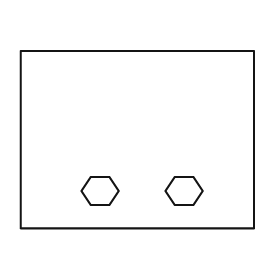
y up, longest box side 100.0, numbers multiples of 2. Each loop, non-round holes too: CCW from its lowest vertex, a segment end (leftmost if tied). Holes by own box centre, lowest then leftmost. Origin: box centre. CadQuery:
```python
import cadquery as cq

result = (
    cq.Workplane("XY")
    .moveTo(-50.0, -38.0)
    .lineTo(50.0, -38.0)
    .lineTo(50.0, 38.0)
    .lineTo(-50.0, 38.0)
    .close()
    .moveTo(-20.0, -28.0)
    .lineTo(-12.0, -28.0)
    .lineTo(-8.0, -22.0)
    .lineTo(-12.0, -16.0)
    .lineTo(-20.0, -16.0)
    .lineTo(-24.0, -22.0)
    .close()
    .moveTo(16.0, -28.0)
    .lineTo(24.0, -28.0)
    .lineTo(28.0, -22.0)
    .lineTo(24.0, -16.0)
    .lineTo(16.0, -16.0)
    .lineTo(12.0, -22.0)
    .close()
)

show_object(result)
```